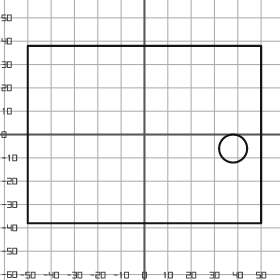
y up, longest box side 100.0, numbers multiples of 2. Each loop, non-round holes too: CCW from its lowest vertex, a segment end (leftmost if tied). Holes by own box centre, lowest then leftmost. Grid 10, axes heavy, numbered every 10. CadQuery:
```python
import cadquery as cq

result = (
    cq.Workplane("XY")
    .moveTo(-50.0, -38.0)
    .lineTo(50.0, -38.0)
    .lineTo(50.0, 38.0)
    .lineTo(-50.0, 38.0)
    .close()
    .moveTo(38.0, -6.0)
    .circle(6.0)
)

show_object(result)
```